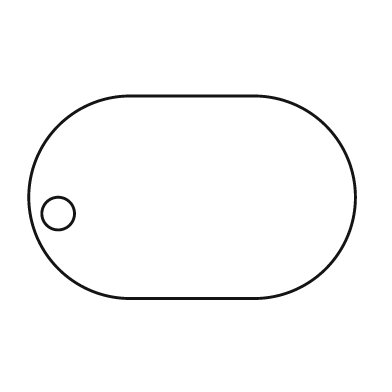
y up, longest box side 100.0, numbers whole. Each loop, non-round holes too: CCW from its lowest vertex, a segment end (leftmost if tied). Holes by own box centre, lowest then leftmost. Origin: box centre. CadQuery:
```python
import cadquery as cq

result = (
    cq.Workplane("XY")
    .moveTo(-19.0, -31.0)
    .lineTo(19.0, -31.0)
    .threePointArc((50.0, 0.0), (19.0, 31.0))
    .lineTo(-19.0, 31.0)
    .threePointArc((-50.0, 0.0), (-19.0, -31.0))
    .close()
    .moveTo(-41.0, -5.0)
    .circle(5.0)
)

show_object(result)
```